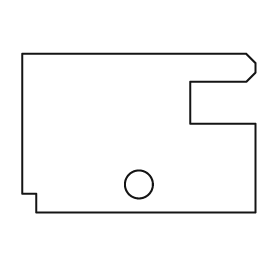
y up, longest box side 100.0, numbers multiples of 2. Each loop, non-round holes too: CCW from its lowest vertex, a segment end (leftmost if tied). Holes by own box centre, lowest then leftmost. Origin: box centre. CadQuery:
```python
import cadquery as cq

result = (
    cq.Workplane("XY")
    .moveTo(-44.0, -34.0)
    .lineTo(50.0, -34.0)
    .lineTo(50.0, 4.0)
    .lineTo(22.0, 4.0)
    .lineTo(22.0, 22.0)
    .lineTo(46.0, 22.0)
    .lineTo(50.0, 26.0)
    .lineTo(50.0, 30.0)
    .lineTo(46.0, 34.0)
    .lineTo(-50.0, 34.0)
    .lineTo(-50.0, -26.0)
    .lineTo(-44.0, -26.0)
    .close()
    .moveTo(0.0, -22.0)
    .circle(6.0)
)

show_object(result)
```